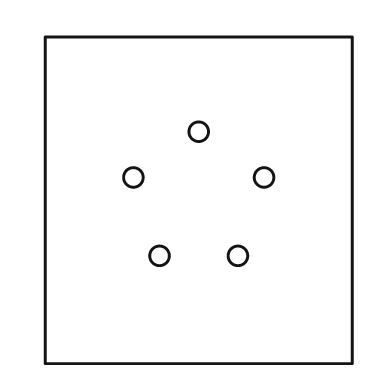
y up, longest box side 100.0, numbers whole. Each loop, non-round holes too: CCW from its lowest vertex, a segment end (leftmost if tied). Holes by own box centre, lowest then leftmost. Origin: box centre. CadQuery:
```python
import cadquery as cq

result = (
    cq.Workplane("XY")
    .moveTo(-47.0, -50.0)
    .lineTo(47.0, -50.0)
    .lineTo(47.0, 50.0)
    .lineTo(-47.0, 50.0)
    .close()
    .moveTo(-12.0, -17.0)
    .circle(3.0)
    .moveTo(12.0, -17.0)
    .circle(3.0)
    .moveTo(-20.0, 7.0)
    .circle(3.0)
    .moveTo(20.0, 7.0)
    .circle(3.0)
    .moveTo(0.0, 21.0)
    .circle(3.0)
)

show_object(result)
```